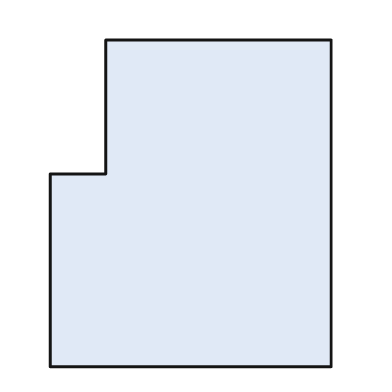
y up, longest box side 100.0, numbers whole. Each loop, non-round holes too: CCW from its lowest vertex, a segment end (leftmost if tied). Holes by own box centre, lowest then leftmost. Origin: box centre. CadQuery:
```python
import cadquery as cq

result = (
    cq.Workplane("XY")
    .moveTo(-43.0, -50.0)
    .lineTo(43.0, -50.0)
    .lineTo(43.0, 50.0)
    .lineTo(-26.0, 50.0)
    .lineTo(-26.0, 9.0)
    .lineTo(-43.0, 9.0)
    .close()
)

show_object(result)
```